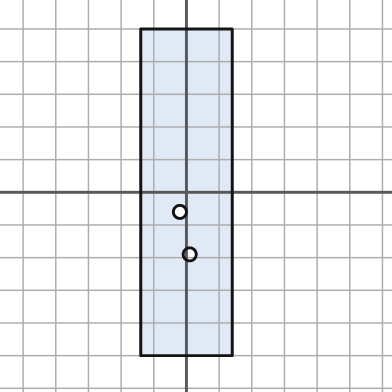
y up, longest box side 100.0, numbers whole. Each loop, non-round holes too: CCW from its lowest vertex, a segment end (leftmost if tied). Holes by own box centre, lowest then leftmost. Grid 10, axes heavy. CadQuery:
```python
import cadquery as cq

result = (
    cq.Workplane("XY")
    .moveTo(-14.0, -50.0)
    .lineTo(14.0, -50.0)
    .lineTo(14.0, 50.0)
    .lineTo(-14.0, 50.0)
    .close()
    .moveTo(1.0, -19.0)
    .circle(2.0)
    .moveTo(-2.0, -6.0)
    .circle(2.0)
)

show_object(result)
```